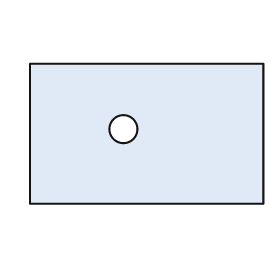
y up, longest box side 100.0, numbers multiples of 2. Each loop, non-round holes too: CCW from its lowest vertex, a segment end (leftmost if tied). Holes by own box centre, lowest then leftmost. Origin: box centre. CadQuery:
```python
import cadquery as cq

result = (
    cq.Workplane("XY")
    .moveTo(-50.0, -30.0)
    .lineTo(50.0, -30.0)
    .lineTo(50.0, 30.0)
    .lineTo(-50.0, 30.0)
    .close()
    .moveTo(-10.0, 2.0)
    .circle(6.0)
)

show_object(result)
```